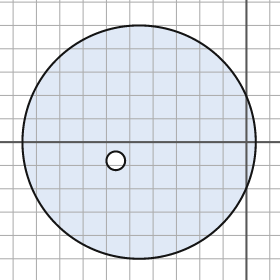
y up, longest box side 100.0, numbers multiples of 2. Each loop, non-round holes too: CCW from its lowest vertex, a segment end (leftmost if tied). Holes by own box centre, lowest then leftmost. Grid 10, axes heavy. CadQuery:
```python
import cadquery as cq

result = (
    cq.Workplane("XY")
    .moveTo(-46.0, 0.0)
    .circle(50.0)
    .moveTo(-56.0, -8.0)
    .circle(4.0)
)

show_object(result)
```